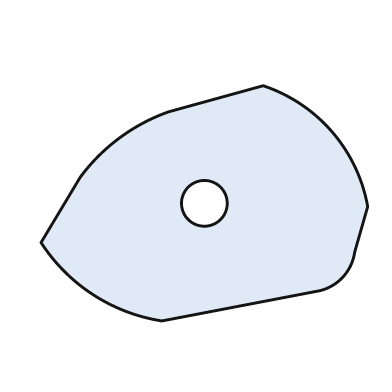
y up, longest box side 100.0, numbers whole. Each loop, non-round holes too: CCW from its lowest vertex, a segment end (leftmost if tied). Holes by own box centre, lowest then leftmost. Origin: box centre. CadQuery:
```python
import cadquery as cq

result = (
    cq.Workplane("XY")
    .moveTo(-13.0, -36.0)
    .lineTo(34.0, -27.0)
    .threePointArc((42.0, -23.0), (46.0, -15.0))
    .lineTo(50.0, -1.0)
    .threePointArc((39.0, 22.0), (18.0, 36.0))
    .lineTo(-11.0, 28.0)
    .threePointArc((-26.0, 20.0), (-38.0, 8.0))
    .lineTo(-50.0, -12.0)
    .threePointArc((-34.0, -28.0), (-13.0, -36.0))
    .close()
    .moveTo(0.0, 0.0)
    .circle(7.0)
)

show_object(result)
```